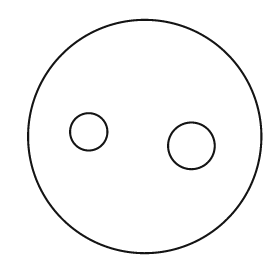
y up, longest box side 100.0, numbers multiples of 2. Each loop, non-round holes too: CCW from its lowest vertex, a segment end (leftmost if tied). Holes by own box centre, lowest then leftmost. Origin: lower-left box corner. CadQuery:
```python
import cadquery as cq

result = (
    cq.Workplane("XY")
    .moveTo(50.0, 50.0)
    .circle(50.0)
    .moveTo(70.0, 46.0)
    .circle(10.0)
    .moveTo(26.0, 52.0)
    .circle(8.0)
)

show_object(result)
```